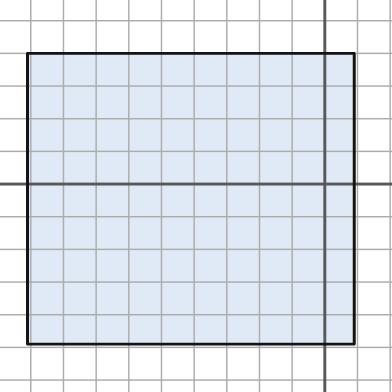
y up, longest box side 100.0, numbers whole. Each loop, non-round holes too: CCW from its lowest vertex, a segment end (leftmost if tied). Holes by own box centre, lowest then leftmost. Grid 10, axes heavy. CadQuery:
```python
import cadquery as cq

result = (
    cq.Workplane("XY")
    .moveTo(-91.0, -49.0)
    .lineTo(9.0, -49.0)
    .lineTo(9.0, 40.0)
    .lineTo(-91.0, 40.0)
    .close()
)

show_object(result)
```